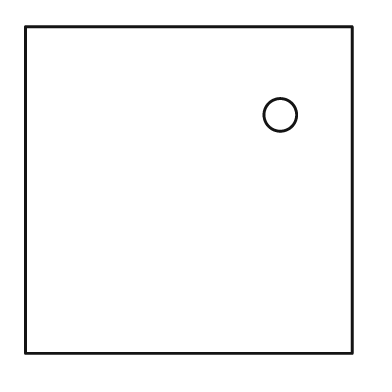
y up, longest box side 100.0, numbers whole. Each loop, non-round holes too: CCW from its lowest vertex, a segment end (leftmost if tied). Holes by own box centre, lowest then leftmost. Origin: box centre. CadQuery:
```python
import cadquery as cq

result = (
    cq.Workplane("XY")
    .moveTo(-50.0, -50.0)
    .lineTo(50.0, -50.0)
    .lineTo(50.0, 50.0)
    .lineTo(-50.0, 50.0)
    .close()
    .moveTo(28.0, 23.0)
    .circle(5.0)
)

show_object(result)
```